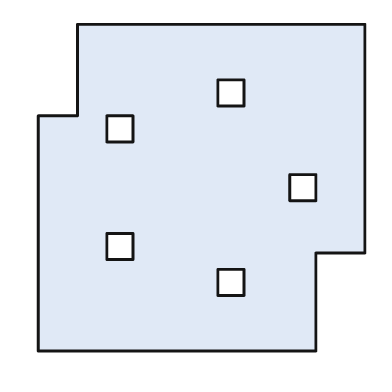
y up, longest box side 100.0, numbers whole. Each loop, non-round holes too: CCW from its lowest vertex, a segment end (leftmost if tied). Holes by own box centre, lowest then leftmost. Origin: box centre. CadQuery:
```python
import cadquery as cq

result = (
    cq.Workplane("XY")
    .moveTo(-50.0, -50.0)
    .lineTo(35.0, -50.0)
    .lineTo(35.0, -20.0)
    .lineTo(50.0, -20.0)
    .lineTo(50.0, 50.0)
    .lineTo(-38.0, 50.0)
    .lineTo(-38.0, 22.0)
    .lineTo(-50.0, 22.0)
    .close()
    .moveTo(5.0, -33.0)
    .lineTo(13.0, -33.0)
    .lineTo(13.0, -25.0)
    .lineTo(5.0, -25.0)
    .close()
    .moveTo(-29.0, -22.0)
    .lineTo(-21.0, -22.0)
    .lineTo(-21.0, -14.0)
    .lineTo(-29.0, -14.0)
    .close()
    .moveTo(27.0, -4.0)
    .lineTo(35.0, -4.0)
    .lineTo(35.0, 4.0)
    .lineTo(27.0, 4.0)
    .close()
    .moveTo(-29.0, 14.0)
    .lineTo(-21.0, 14.0)
    .lineTo(-21.0, 22.0)
    .lineTo(-29.0, 22.0)
    .close()
    .moveTo(5.0, 25.0)
    .lineTo(13.0, 25.0)
    .lineTo(13.0, 33.0)
    .lineTo(5.0, 33.0)
    .close()
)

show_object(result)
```